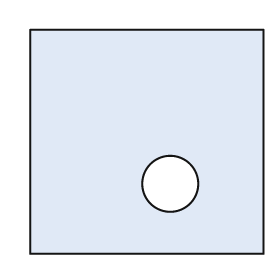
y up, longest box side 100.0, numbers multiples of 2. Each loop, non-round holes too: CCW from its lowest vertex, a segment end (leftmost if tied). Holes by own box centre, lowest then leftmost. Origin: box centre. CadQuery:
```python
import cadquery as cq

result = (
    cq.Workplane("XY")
    .moveTo(-50.0, -48.0)
    .lineTo(50.0, -48.0)
    .lineTo(50.0, 48.0)
    .lineTo(-50.0, 48.0)
    .close()
    .moveTo(10.0, -18.0)
    .circle(12.0)
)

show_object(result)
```